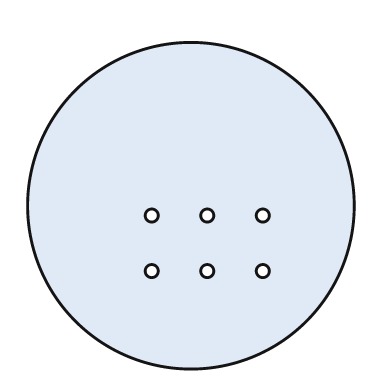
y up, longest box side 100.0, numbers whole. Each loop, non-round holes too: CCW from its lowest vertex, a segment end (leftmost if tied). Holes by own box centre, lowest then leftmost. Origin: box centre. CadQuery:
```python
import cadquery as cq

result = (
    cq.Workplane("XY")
    .moveTo(0.0, 0.0)
    .circle(50.0)
    .moveTo(-12.0, -20.0)
    .circle(2.0)
    .moveTo(5.0, -20.0)
    .circle(2.0)
    .moveTo(22.0, -20.0)
    .circle(2.0)
    .moveTo(-12.0, -3.0)
    .circle(2.0)
    .moveTo(5.0, -3.0)
    .circle(2.0)
    .moveTo(22.0, -3.0)
    .circle(2.0)
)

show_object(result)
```